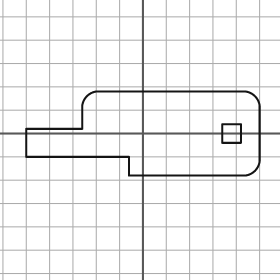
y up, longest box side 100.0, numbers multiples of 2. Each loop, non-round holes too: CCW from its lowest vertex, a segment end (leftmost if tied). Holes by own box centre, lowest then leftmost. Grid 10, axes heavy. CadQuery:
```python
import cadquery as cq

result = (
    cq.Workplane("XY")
    .moveTo(-6.0, -18.0)
    .lineTo(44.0, -18.0)
    .threePointArc((48.0, -16.0), (50.0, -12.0))
    .lineTo(50.0, 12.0)
    .threePointArc((48.0, 16.0), (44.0, 18.0))
    .lineTo(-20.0, 18.0)
    .threePointArc((-24.0, 16.0), (-26.0, 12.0))
    .lineTo(-26.0, 2.0)
    .lineTo(-50.0, 2.0)
    .lineTo(-50.0, -10.0)
    .lineTo(-6.0, -10.0)
    .close()
    .moveTo(34.0, -4.0)
    .lineTo(42.0, -4.0)
    .lineTo(42.0, 4.0)
    .lineTo(34.0, 4.0)
    .close()
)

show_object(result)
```